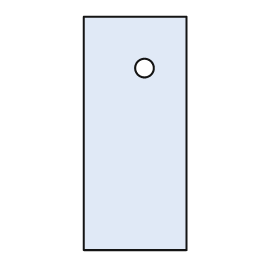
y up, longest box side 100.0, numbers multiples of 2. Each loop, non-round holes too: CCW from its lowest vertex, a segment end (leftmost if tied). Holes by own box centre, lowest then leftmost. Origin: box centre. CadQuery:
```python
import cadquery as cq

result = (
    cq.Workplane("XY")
    .moveTo(-22.0, -50.0)
    .lineTo(22.0, -50.0)
    .lineTo(22.0, 50.0)
    .lineTo(-22.0, 50.0)
    .close()
    .moveTo(4.0, 28.0)
    .circle(4.0)
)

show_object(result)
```